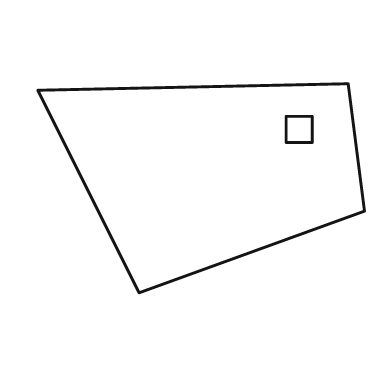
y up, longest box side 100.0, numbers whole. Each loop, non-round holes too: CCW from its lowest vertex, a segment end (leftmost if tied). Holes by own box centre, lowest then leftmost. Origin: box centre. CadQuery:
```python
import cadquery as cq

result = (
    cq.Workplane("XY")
    .moveTo(-19.0, -32.0)
    .lineTo(50.0, -7.0)
    .lineTo(45.0, 32.0)
    .lineTo(-50.0, 30.0)
    .close()
    .moveTo(26.0, 14.0)
    .lineTo(34.0, 14.0)
    .lineTo(34.0, 22.0)
    .lineTo(26.0, 22.0)
    .close()
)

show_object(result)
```